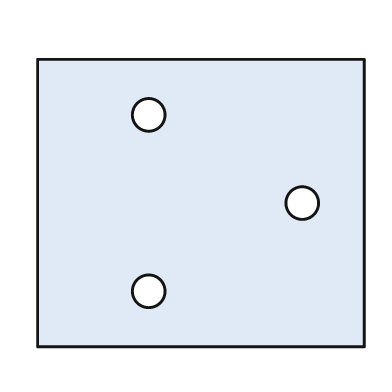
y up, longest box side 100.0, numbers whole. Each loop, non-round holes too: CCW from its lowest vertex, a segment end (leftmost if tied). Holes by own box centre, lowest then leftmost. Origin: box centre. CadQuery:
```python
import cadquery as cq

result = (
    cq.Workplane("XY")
    .moveTo(-50.0, -44.0)
    .lineTo(50.0, -44.0)
    .lineTo(50.0, 44.0)
    .lineTo(-50.0, 44.0)
    .close()
    .moveTo(-16.0, -27.0)
    .circle(5.0)
    .moveTo(31.0, 0.0)
    .circle(5.0)
    .moveTo(-16.0, 27.0)
    .circle(5.0)
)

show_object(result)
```